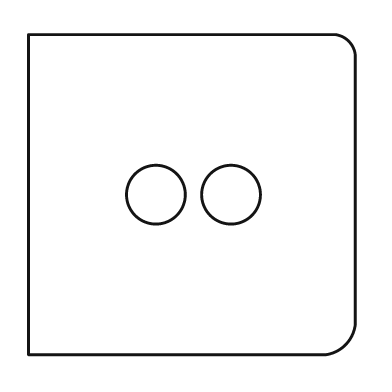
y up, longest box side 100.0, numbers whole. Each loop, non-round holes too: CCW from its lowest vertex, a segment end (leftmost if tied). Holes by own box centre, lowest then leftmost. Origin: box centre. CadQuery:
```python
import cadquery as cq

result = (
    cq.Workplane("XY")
    .moveTo(-50.0, -49.0)
    .lineTo(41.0, -49.0)
    .threePointArc((47.0, -46.0), (50.0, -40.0))
    .lineTo(50.0, 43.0)
    .threePointArc((48.0, 47.0), (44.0, 49.0))
    .lineTo(-50.0, 49.0)
    .close()
    .moveTo(-11.0, 0.0)
    .circle(9.0)
    .moveTo(12.0, 0.0)
    .circle(9.0)
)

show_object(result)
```